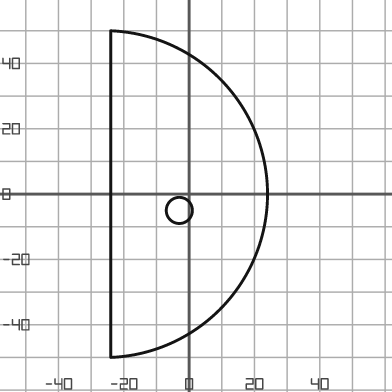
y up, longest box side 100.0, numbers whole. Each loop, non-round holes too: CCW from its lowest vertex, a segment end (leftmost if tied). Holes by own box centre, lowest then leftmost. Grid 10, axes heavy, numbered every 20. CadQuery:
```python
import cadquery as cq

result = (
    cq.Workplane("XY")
    .moveTo(-24.0, -50.0)
    .threePointArc((24.0, 0.0), (-24.0, 50.0))
    .close()
    .moveTo(-3.0, -5.0)
    .circle(4.0)
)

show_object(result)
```